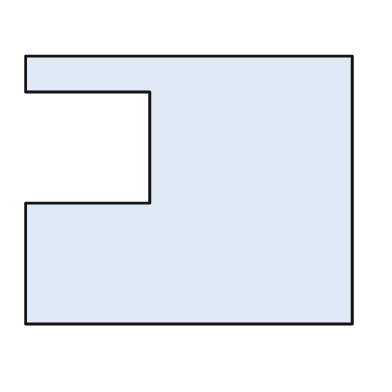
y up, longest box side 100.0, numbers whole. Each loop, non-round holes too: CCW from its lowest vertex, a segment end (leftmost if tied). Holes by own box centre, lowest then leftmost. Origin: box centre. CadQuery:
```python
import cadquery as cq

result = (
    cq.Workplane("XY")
    .moveTo(-50.0, -41.0)
    .lineTo(50.0, -41.0)
    .lineTo(50.0, 41.0)
    .lineTo(-50.0, 41.0)
    .lineTo(-50.0, 30.0)
    .lineTo(-12.0, 30.0)
    .lineTo(-12.0, -4.0)
    .lineTo(-50.0, -4.0)
    .close()
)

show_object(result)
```